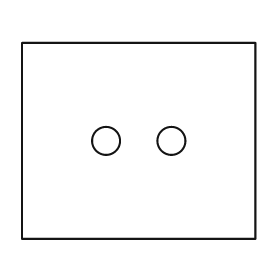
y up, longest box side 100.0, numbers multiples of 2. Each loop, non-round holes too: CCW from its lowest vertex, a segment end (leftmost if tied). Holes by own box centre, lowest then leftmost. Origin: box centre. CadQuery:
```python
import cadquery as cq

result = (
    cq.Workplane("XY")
    .moveTo(-50.0, -42.0)
    .lineTo(50.0, -42.0)
    .lineTo(50.0, 42.0)
    .lineTo(-50.0, 42.0)
    .close()
    .moveTo(-14.0, 0.0)
    .circle(6.0)
    .moveTo(14.0, 0.0)
    .circle(6.0)
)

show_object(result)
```